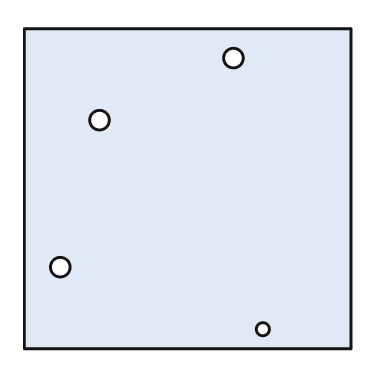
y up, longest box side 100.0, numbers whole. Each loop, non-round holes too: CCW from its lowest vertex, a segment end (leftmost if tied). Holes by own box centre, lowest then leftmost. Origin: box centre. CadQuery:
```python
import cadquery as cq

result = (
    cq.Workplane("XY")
    .moveTo(-50.0, -49.0)
    .lineTo(50.0, -49.0)
    .lineTo(50.0, 49.0)
    .lineTo(-50.0, 49.0)
    .close()
    .moveTo(23.0, -43.0)
    .circle(2.0)
    .moveTo(-39.0, -24.0)
    .circle(3.0)
    .moveTo(-27.0, 21.0)
    .circle(3.0)
    .moveTo(14.0, 40.0)
    .circle(3.0)
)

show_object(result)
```